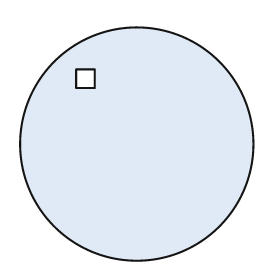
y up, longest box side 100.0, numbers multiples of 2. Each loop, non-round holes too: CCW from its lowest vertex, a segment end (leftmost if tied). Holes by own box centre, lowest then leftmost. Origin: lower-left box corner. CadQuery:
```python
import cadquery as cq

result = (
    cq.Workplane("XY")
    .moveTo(50.0, 50.0)
    .circle(50.0)
    .moveTo(24.0, 74.0)
    .lineTo(32.0, 74.0)
    .lineTo(32.0, 82.0)
    .lineTo(24.0, 82.0)
    .close()
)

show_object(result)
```